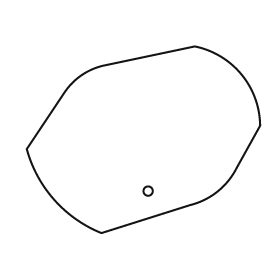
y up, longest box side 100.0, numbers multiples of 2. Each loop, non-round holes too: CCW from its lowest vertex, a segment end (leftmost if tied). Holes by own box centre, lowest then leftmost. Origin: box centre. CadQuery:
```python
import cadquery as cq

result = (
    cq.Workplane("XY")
    .moveTo(-18.0, -40.0)
    .lineTo(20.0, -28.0)
    .threePointArc((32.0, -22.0), (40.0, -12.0))
    .lineTo(50.0, 6.0)
    .threePointArc((42.0, 28.0), (22.0, 40.0))
    .lineTo(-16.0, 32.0)
    .threePointArc((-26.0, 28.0), (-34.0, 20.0))
    .lineTo(-50.0, -4.0)
    .threePointArc((-38.0, -26.0), (-18.0, -40.0))
    .close()
    .moveTo(2.0, -22.0)
    .circle(2.0)
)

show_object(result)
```